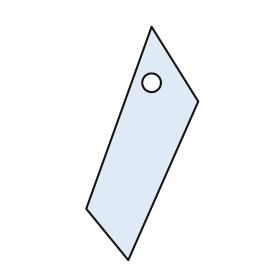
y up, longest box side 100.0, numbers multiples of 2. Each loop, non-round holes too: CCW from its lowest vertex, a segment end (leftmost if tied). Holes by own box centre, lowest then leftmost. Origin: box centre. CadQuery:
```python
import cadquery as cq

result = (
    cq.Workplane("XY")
    .moveTo(-6.0, -50.0)
    .lineTo(24.0, 18.0)
    .lineTo(4.0, 50.0)
    .lineTo(-24.0, -28.0)
    .close()
    .moveTo(4.0, 26.0)
    .circle(4.0)
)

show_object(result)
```